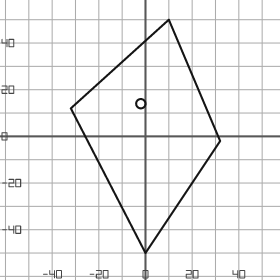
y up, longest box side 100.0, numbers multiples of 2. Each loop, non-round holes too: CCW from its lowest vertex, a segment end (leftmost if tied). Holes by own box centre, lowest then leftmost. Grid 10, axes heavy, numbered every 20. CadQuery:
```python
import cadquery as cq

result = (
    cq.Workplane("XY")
    .moveTo(0.0, -50.0)
    .lineTo(32.0, -2.0)
    .lineTo(10.0, 50.0)
    .lineTo(-32.0, 12.0)
    .close()
    .moveTo(-2.0, 14.0)
    .circle(2.0)
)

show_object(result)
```